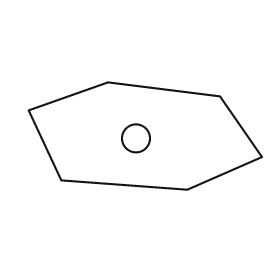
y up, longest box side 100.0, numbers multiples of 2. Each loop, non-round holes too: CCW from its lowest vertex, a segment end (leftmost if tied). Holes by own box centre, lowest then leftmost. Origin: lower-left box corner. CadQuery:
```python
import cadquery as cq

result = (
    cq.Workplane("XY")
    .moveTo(68.0, 0.0)
    .lineTo(100.0, 14.0)
    .lineTo(82.0, 40.0)
    .lineTo(34.0, 46.0)
    .lineTo(0.0, 34.0)
    .lineTo(14.0, 4.0)
    .close()
    .moveTo(46.0, 22.0)
    .circle(6.0)
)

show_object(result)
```